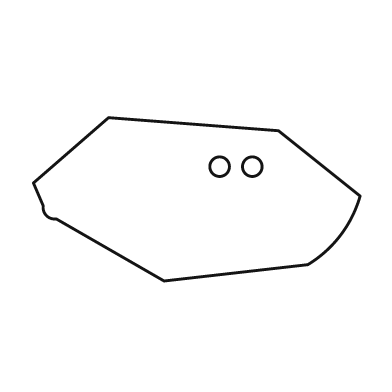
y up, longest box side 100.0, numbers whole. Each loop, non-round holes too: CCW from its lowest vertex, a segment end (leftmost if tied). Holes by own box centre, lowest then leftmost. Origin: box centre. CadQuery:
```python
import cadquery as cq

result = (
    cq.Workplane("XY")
    .moveTo(-10.0, -25.0)
    .lineTo(34.0, -20.0)
    .threePointArc((44.0, -11.0), (50.0, 1.0))
    .lineTo(25.0, 21.0)
    .lineTo(-27.0, 25.0)
    .lineTo(-50.0, 5.0)
    .lineTo(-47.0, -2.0)
    .threePointArc((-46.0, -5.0), (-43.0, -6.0))
    .close()
    .moveTo(7.0, 10.0)
    .circle(3.0)
    .moveTo(17.0, 10.0)
    .circle(3.0)
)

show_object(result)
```